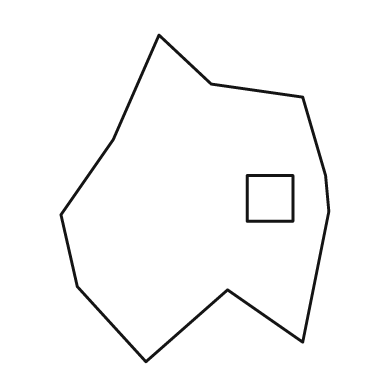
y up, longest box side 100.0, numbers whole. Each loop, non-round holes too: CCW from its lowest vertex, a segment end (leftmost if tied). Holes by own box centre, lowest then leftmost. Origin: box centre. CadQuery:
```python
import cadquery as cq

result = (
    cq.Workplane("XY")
    .moveTo(-15.0, -50.0)
    .lineTo(10.0, -28.0)
    .lineTo(33.0, -44.0)
    .lineTo(41.0, -4.0)
    .lineTo(40.0, 7.0)
    .lineTo(33.0, 31.0)
    .lineTo(5.0, 35.0)
    .lineTo(-11.0, 50.0)
    .lineTo(-25.0, 18.0)
    .lineTo(-41.0, -5.0)
    .lineTo(-36.0, -27.0)
    .close()
    .moveTo(16.0, -7.0)
    .lineTo(30.0, -7.0)
    .lineTo(30.0, 7.0)
    .lineTo(16.0, 7.0)
    .close()
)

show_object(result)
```